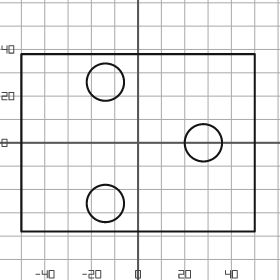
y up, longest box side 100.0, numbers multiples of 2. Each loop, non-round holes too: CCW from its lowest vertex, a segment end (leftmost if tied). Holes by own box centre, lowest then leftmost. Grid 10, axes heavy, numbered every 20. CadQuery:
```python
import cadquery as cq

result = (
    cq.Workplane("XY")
    .moveTo(-50.0, -38.0)
    .lineTo(50.0, -38.0)
    .lineTo(50.0, 38.0)
    .lineTo(-50.0, 38.0)
    .close()
    .moveTo(-14.0, -26.0)
    .circle(8.0)
    .moveTo(28.0, 0.0)
    .circle(8.0)
    .moveTo(-14.0, 26.0)
    .circle(8.0)
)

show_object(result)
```